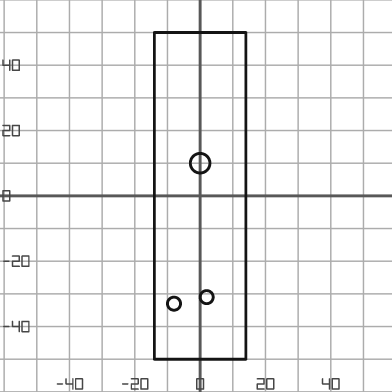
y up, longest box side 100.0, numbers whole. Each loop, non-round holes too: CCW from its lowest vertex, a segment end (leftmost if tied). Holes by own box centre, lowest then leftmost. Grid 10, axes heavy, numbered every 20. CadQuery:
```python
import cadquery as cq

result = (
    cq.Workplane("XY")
    .moveTo(-14.0, -50.0)
    .lineTo(14.0, -50.0)
    .lineTo(14.0, 50.0)
    .lineTo(-14.0, 50.0)
    .close()
    .moveTo(-8.0, -33.0)
    .circle(2.0)
    .moveTo(2.0, -31.0)
    .circle(2.0)
    .moveTo(0.0, 10.0)
    .circle(3.0)
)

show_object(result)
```